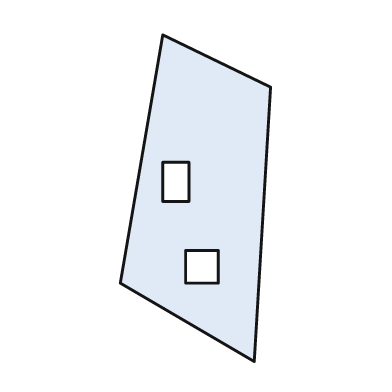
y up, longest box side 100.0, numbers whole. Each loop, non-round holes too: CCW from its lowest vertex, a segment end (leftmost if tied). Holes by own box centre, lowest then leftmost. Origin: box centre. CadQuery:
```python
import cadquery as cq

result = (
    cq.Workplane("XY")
    .moveTo(18.0, -50.0)
    .lineTo(23.0, 34.0)
    .lineTo(-10.0, 50.0)
    .lineTo(-23.0, -26.0)
    .close()
    .moveTo(-3.0, -26.0)
    .lineTo(7.0, -26.0)
    .lineTo(7.0, -16.0)
    .lineTo(-3.0, -16.0)
    .close()
    .moveTo(-10.0, -1.0)
    .lineTo(-2.0, -1.0)
    .lineTo(-2.0, 11.0)
    .lineTo(-10.0, 11.0)
    .close()
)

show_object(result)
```